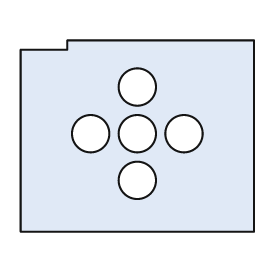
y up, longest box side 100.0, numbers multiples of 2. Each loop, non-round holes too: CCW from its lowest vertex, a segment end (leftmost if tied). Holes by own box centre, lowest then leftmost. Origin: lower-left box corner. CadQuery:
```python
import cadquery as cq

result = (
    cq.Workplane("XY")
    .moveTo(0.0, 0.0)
    .lineTo(100.0, 0.0)
    .lineTo(100.0, 82.0)
    .lineTo(20.0, 82.0)
    .lineTo(20.0, 78.0)
    .lineTo(0.0, 78.0)
    .close()
    .moveTo(50.0, 22.0)
    .circle(8.0)
    .moveTo(30.0, 42.0)
    .circle(8.0)
    .moveTo(50.0, 42.0)
    .circle(8.0)
    .moveTo(70.0, 42.0)
    .circle(8.0)
    .moveTo(50.0, 62.0)
    .circle(8.0)
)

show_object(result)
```